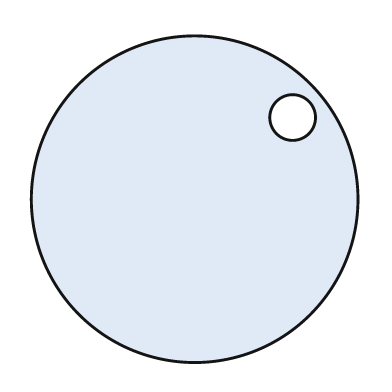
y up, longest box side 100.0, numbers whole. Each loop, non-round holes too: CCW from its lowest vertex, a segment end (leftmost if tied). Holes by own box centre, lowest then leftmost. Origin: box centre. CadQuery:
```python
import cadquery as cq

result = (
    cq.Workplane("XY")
    .moveTo(0.0, 0.0)
    .circle(50.0)
    .moveTo(30.0, 25.0)
    .circle(7.0)
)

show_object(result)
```